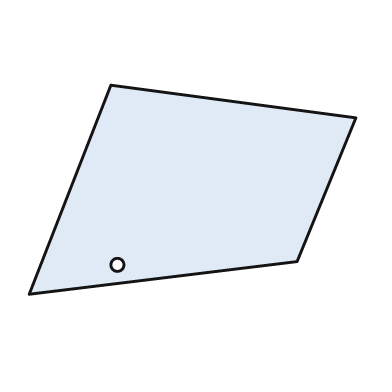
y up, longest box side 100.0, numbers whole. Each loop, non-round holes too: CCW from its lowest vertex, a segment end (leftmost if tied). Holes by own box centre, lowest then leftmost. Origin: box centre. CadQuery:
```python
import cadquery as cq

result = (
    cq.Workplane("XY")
    .moveTo(-50.0, -32.0)
    .lineTo(32.0, -22.0)
    .lineTo(50.0, 22.0)
    .lineTo(-25.0, 32.0)
    .close()
    .moveTo(-23.0, -23.0)
    .circle(2.0)
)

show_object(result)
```